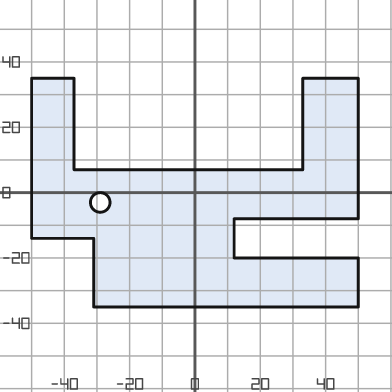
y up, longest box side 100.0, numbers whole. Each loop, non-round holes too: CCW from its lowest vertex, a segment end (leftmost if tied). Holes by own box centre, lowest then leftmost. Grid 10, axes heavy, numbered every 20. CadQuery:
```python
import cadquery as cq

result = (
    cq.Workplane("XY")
    .moveTo(-31.0, -35.0)
    .lineTo(50.0, -35.0)
    .lineTo(50.0, -20.0)
    .lineTo(12.0, -20.0)
    .lineTo(12.0, -8.0)
    .lineTo(50.0, -8.0)
    .lineTo(50.0, 35.0)
    .lineTo(33.0, 35.0)
    .lineTo(33.0, 7.0)
    .lineTo(-37.0, 7.0)
    .lineTo(-37.0, 35.0)
    .lineTo(-50.0, 35.0)
    .lineTo(-50.0, -14.0)
    .lineTo(-31.0, -14.0)
    .close()
    .moveTo(-29.0, -3.0)
    .circle(3.0)
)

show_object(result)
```